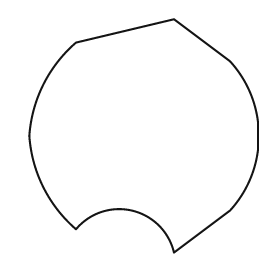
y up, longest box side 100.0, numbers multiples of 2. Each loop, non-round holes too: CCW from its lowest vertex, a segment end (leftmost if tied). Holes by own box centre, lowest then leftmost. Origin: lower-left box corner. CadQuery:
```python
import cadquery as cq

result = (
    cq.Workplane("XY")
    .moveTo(62.0, 0.0)
    .lineTo(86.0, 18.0)
    .threePointArc((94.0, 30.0), (98.0, 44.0))
    .lineTo(98.0, 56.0)
    .threePointArc((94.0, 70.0), (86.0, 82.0))
    .lineTo(62.0, 100.0)
    .lineTo(20.0, 90.0)
    .threePointArc((6.0, 72.0), (0.0, 50.0))
    .threePointArc((6.0, 28.0), (20.0, 10.0))
    .threePointArc((44.0, 18.0), (62.0, 0.0))
    .close()
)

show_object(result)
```